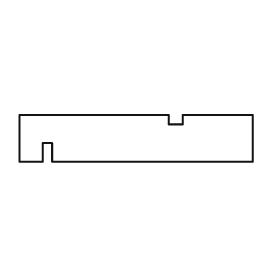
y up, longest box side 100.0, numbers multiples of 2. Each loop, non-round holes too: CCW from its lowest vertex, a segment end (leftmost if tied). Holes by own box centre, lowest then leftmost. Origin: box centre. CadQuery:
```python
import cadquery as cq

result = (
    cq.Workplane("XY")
    .moveTo(-50.0, -10.0)
    .lineTo(-40.0, -10.0)
    .lineTo(-40.0, -2.0)
    .lineTo(-36.0, -2.0)
    .lineTo(-36.0, -10.0)
    .lineTo(50.0, -10.0)
    .lineTo(50.0, 10.0)
    .lineTo(20.0, 10.0)
    .lineTo(20.0, 6.0)
    .lineTo(14.0, 6.0)
    .lineTo(14.0, 10.0)
    .lineTo(-50.0, 10.0)
    .close()
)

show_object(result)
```